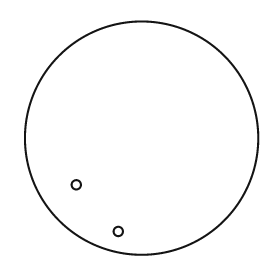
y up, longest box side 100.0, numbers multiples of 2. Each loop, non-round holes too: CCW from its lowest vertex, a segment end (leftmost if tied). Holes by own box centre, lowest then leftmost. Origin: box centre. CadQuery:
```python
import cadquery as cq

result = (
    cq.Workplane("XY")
    .moveTo(0.0, 0.0)
    .circle(50.0)
    .moveTo(-10.0, -40.0)
    .circle(2.0)
    .moveTo(-28.0, -20.0)
    .circle(2.0)
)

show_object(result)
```